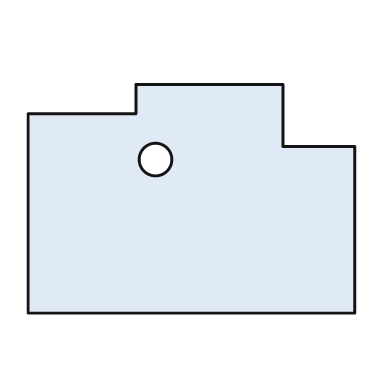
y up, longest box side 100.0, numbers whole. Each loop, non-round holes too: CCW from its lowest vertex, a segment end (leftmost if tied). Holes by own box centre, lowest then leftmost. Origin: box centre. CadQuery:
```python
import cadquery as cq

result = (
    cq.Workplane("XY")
    .moveTo(-50.0, -35.0)
    .lineTo(50.0, -35.0)
    .lineTo(50.0, 16.0)
    .lineTo(28.0, 16.0)
    .lineTo(28.0, 35.0)
    .lineTo(-17.0, 35.0)
    .lineTo(-17.0, 26.0)
    .lineTo(-50.0, 26.0)
    .close()
    .moveTo(-11.0, 12.0)
    .circle(5.0)
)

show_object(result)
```